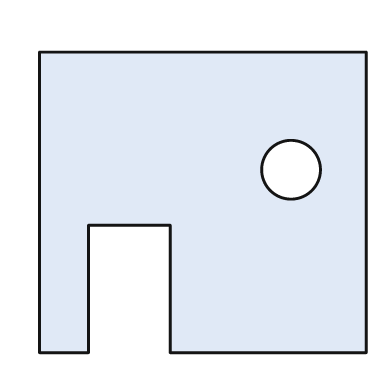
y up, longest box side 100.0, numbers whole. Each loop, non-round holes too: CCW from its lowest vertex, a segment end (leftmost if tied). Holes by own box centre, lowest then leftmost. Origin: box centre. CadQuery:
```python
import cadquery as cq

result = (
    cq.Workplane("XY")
    .moveTo(-50.0, -46.0)
    .lineTo(-35.0, -46.0)
    .lineTo(-35.0, -7.0)
    .lineTo(-10.0, -7.0)
    .lineTo(-10.0, -46.0)
    .lineTo(50.0, -46.0)
    .lineTo(50.0, 46.0)
    .lineTo(-50.0, 46.0)
    .close()
    .moveTo(27.0, 10.0)
    .circle(9.0)
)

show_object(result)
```